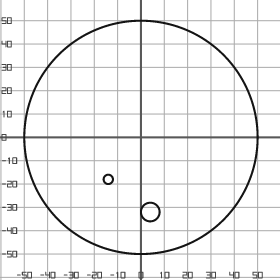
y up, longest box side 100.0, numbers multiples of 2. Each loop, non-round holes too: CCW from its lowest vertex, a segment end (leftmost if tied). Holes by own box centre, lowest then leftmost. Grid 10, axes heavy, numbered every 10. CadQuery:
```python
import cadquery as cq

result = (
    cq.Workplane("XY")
    .moveTo(0.0, 0.0)
    .circle(50.0)
    .moveTo(4.0, -32.0)
    .circle(4.0)
    .moveTo(-14.0, -18.0)
    .circle(2.0)
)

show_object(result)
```